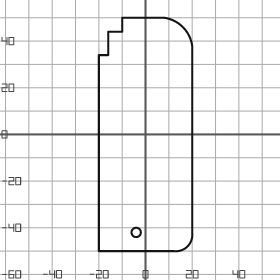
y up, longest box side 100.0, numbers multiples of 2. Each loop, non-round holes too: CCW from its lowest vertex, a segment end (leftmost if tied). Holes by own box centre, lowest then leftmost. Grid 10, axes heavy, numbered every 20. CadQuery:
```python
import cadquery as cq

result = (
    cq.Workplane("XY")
    .moveTo(-20.0, -50.0)
    .lineTo(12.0, -50.0)
    .threePointArc((18.0, -48.0), (20.0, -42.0))
    .lineTo(20.0, 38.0)
    .threePointArc((16.0, 46.0), (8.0, 50.0))
    .lineTo(-10.0, 50.0)
    .lineTo(-10.0, 44.0)
    .lineTo(-16.0, 44.0)
    .lineTo(-16.0, 34.0)
    .lineTo(-20.0, 34.0)
    .close()
    .moveTo(-4.0, -42.0)
    .circle(2.0)
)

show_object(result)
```